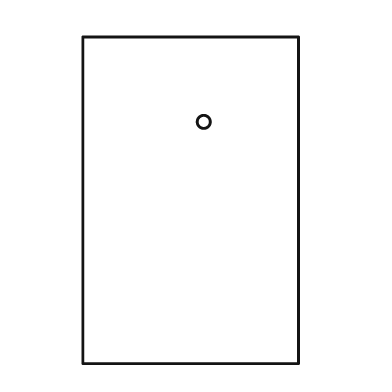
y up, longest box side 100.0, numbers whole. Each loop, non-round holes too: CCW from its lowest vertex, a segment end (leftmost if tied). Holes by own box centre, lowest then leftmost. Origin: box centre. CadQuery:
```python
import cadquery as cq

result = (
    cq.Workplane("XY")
    .moveTo(-33.0, -50.0)
    .lineTo(33.0, -50.0)
    .lineTo(33.0, 50.0)
    .lineTo(-33.0, 50.0)
    .close()
    .moveTo(4.0, 24.0)
    .circle(2.0)
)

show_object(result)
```